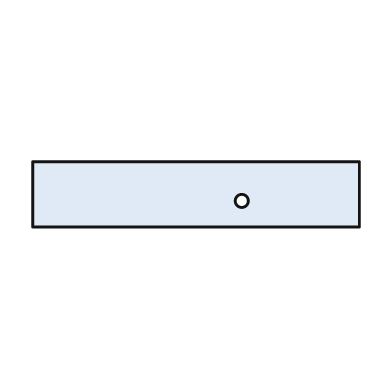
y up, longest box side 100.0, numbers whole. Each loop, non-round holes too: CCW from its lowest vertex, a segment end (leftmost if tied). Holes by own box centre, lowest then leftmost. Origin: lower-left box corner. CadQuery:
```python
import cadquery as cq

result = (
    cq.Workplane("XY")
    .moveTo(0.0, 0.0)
    .lineTo(100.0, 0.0)
    .lineTo(100.0, 20.0)
    .lineTo(0.0, 20.0)
    .close()
    .moveTo(64.0, 8.0)
    .circle(2.0)
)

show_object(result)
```